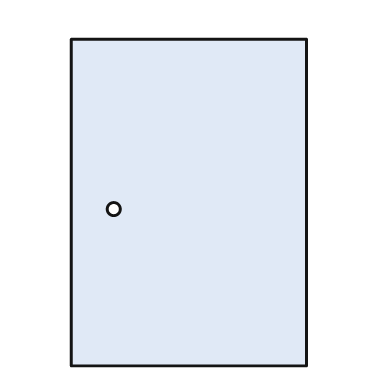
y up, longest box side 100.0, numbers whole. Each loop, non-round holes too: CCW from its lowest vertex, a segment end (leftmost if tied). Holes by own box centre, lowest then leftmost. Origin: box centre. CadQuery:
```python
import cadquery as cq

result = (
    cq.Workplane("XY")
    .moveTo(-36.0, -50.0)
    .lineTo(36.0, -50.0)
    .lineTo(36.0, 50.0)
    .lineTo(-36.0, 50.0)
    .close()
    .moveTo(-23.0, -2.0)
    .circle(2.0)
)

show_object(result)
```